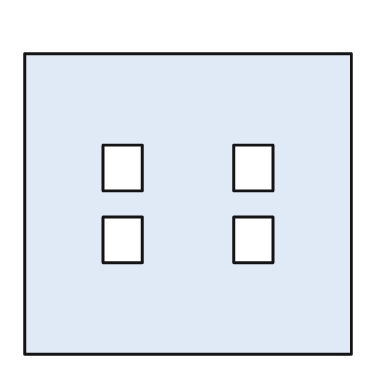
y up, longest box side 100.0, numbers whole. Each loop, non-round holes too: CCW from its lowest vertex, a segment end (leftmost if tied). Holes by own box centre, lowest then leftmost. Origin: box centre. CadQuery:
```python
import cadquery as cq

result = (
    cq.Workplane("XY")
    .moveTo(-50.0, -46.0)
    .lineTo(50.0, -46.0)
    .lineTo(50.0, 46.0)
    .lineTo(-50.0, 46.0)
    .close()
    .moveTo(-26.0, -18.0)
    .lineTo(-14.0, -18.0)
    .lineTo(-14.0, -4.0)
    .lineTo(-26.0, -4.0)
    .close()
    .moveTo(14.0, -18.0)
    .lineTo(26.0, -18.0)
    .lineTo(26.0, -4.0)
    .lineTo(14.0, -4.0)
    .close()
    .moveTo(-26.0, 4.0)
    .lineTo(-14.0, 4.0)
    .lineTo(-14.0, 18.0)
    .lineTo(-26.0, 18.0)
    .close()
    .moveTo(14.0, 4.0)
    .lineTo(26.0, 4.0)
    .lineTo(26.0, 18.0)
    .lineTo(14.0, 18.0)
    .close()
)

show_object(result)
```